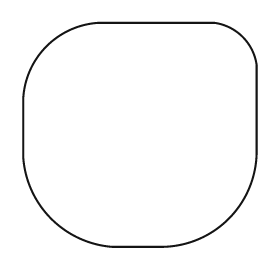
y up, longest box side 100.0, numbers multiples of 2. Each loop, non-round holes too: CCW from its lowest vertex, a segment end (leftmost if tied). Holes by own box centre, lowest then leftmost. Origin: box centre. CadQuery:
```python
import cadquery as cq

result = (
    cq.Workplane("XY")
    .moveTo(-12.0, -48.0)
    .lineTo(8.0, -48.0)
    .threePointArc((38.0, -36.0), (50.0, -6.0))
    .lineTo(50.0, 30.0)
    .threePointArc((44.0, 42.0), (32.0, 48.0))
    .lineTo(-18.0, 48.0)
    .threePointArc((-40.0, 38.0), (-50.0, 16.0))
    .lineTo(-50.0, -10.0)
    .threePointArc((-38.0, -36.0), (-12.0, -48.0))
    .close()
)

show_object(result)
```